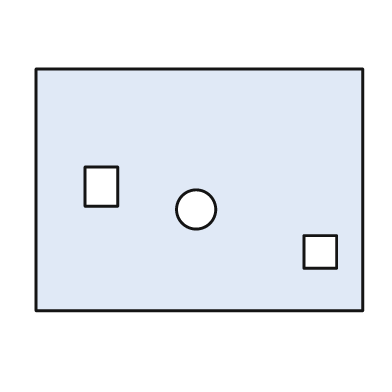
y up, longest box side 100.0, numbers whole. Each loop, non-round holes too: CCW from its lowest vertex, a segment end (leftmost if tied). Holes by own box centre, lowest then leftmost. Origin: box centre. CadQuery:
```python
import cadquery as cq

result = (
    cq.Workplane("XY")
    .moveTo(-50.0, -37.0)
    .lineTo(50.0, -37.0)
    .lineTo(50.0, 37.0)
    .lineTo(-50.0, 37.0)
    .close()
    .moveTo(32.0, -24.0)
    .lineTo(42.0, -24.0)
    .lineTo(42.0, -14.0)
    .lineTo(32.0, -14.0)
    .close()
    .moveTo(-1.0, -6.0)
    .circle(6.0)
    .moveTo(-35.0, -5.0)
    .lineTo(-25.0, -5.0)
    .lineTo(-25.0, 7.0)
    .lineTo(-35.0, 7.0)
    .close()
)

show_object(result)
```